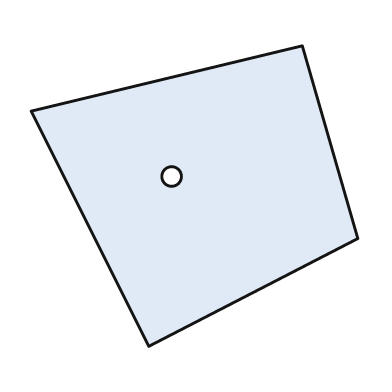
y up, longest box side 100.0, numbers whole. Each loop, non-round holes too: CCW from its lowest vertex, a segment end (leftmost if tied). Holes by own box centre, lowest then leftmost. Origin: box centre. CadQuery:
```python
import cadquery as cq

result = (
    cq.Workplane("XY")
    .moveTo(-14.0, -46.0)
    .lineTo(50.0, -13.0)
    .lineTo(33.0, 46.0)
    .lineTo(-50.0, 26.0)
    .close()
    .moveTo(-7.0, 6.0)
    .circle(3.0)
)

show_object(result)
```